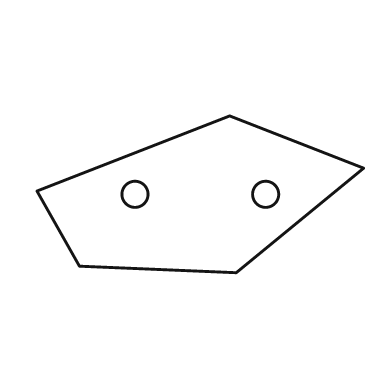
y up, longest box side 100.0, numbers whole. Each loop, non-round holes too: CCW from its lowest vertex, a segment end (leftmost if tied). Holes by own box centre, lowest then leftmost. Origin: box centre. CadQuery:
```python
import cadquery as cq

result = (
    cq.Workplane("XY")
    .moveTo(11.0, -24.0)
    .lineTo(50.0, 8.0)
    .lineTo(9.0, 24.0)
    .lineTo(-50.0, 1.0)
    .lineTo(-37.0, -22.0)
    .close()
    .moveTo(-20.0, 0.0)
    .circle(4.0)
    .moveTo(20.0, 0.0)
    .circle(4.0)
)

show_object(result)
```